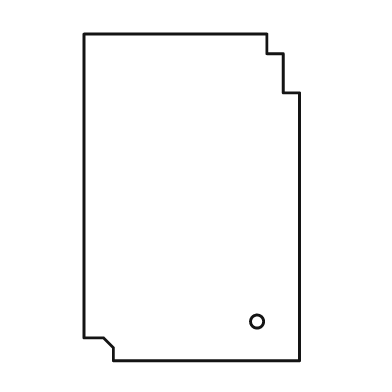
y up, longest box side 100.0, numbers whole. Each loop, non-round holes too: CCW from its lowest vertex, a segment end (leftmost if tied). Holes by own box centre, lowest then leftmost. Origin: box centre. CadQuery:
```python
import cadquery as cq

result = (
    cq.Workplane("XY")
    .moveTo(-24.0, -50.0)
    .lineTo(33.0, -50.0)
    .lineTo(33.0, 32.0)
    .lineTo(28.0, 32.0)
    .lineTo(28.0, 44.0)
    .lineTo(23.0, 44.0)
    .lineTo(23.0, 50.0)
    .lineTo(-33.0, 50.0)
    .lineTo(-33.0, -43.0)
    .lineTo(-27.0, -43.0)
    .lineTo(-24.0, -46.0)
    .close()
    .moveTo(20.0, -38.0)
    .circle(2.0)
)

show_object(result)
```